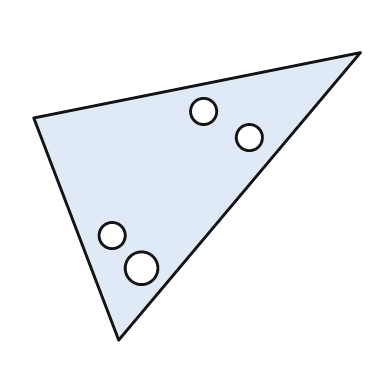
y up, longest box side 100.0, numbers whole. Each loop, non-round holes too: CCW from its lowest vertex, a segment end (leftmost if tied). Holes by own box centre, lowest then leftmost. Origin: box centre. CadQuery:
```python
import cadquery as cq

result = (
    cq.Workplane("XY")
    .moveTo(-24.0, -44.0)
    .lineTo(50.0, 44.0)
    .lineTo(-50.0, 24.0)
    .close()
    .moveTo(-17.0, -22.0)
    .circle(5.0)
    .moveTo(-26.0, -12.0)
    .circle(4.0)
    .moveTo(16.0, 18.0)
    .circle(4.0)
    .moveTo(2.0, 26.0)
    .circle(4.0)
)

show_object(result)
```